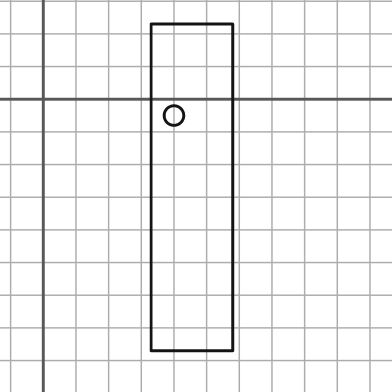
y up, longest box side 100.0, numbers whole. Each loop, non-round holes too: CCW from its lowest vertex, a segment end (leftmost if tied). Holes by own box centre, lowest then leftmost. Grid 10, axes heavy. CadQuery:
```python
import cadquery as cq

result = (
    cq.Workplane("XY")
    .moveTo(33.0, -77.0)
    .lineTo(58.0, -77.0)
    .lineTo(58.0, 23.0)
    .lineTo(33.0, 23.0)
    .close()
    .moveTo(40.0, -5.0)
    .circle(3.0)
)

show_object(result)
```